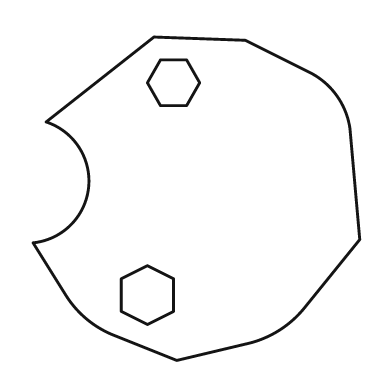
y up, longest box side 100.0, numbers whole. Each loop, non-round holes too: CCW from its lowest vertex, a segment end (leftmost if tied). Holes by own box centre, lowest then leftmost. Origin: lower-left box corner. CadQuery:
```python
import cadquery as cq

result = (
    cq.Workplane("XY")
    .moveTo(44.0, 0.0)
    .lineTo(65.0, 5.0)
    .threePointArc((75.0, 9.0), (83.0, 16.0))
    .lineTo(100.0, 37.0)
    .lineTo(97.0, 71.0)
    .threePointArc((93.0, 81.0), (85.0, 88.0))
    .lineTo(65.0, 98.0)
    .lineTo(37.0, 99.0)
    .lineTo(4.0, 73.0)
    .threePointArc((17.0, 53.0), (0.0, 36.0))
    .lineTo(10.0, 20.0)
    .threePointArc((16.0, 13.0), (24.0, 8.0))
    .close()
    .moveTo(35.0, 11.0)
    .lineTo(43.0, 15.0)
    .lineTo(43.0, 25.0)
    .lineTo(35.0, 29.0)
    .lineTo(27.0, 25.0)
    .lineTo(27.0, 15.0)
    .close()
    .moveTo(39.0, 78.0)
    .lineTo(47.0, 78.0)
    .lineTo(51.0, 85.0)
    .lineTo(47.0, 92.0)
    .lineTo(39.0, 92.0)
    .lineTo(35.0, 85.0)
    .close()
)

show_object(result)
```